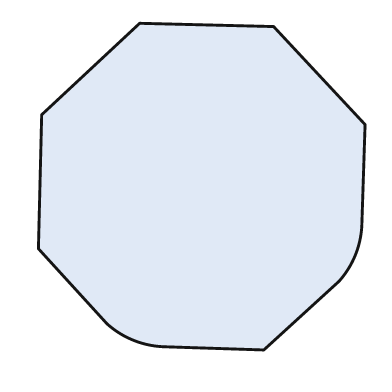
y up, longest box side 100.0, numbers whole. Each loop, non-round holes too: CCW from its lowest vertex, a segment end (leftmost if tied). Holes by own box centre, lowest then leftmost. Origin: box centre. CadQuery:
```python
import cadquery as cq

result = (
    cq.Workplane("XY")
    .moveTo(19.0, -50.0)
    .lineTo(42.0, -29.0)
    .threePointArc((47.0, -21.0), (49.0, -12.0))
    .lineTo(50.0, 19.0)
    .lineTo(22.0, 49.0)
    .lineTo(-19.0, 50.0)
    .lineTo(-49.0, 22.0)
    .lineTo(-50.0, -19.0)
    .lineTo(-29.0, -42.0)
    .threePointArc((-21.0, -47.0), (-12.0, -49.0))
    .close()
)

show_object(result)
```